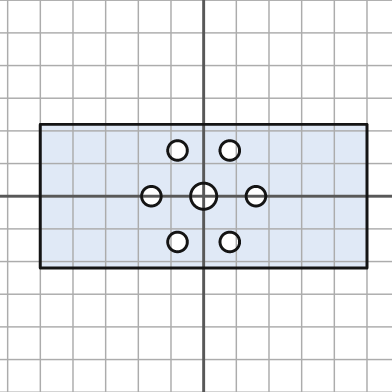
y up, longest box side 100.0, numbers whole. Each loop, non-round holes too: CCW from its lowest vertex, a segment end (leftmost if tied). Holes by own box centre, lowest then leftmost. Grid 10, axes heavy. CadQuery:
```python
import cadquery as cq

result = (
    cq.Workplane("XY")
    .moveTo(-50.0, -22.0)
    .lineTo(50.0, -22.0)
    .lineTo(50.0, 22.0)
    .lineTo(-50.0, 22.0)
    .close()
    .moveTo(-8.0, -14.0)
    .circle(3.0)
    .moveTo(8.0, -14.0)
    .circle(3.0)
    .moveTo(-16.0, 0.0)
    .circle(3.0)
    .moveTo(0.0, 0.0)
    .circle(4.0)
    .moveTo(16.0, 0.0)
    .circle(3.0)
    .moveTo(-8.0, 14.0)
    .circle(3.0)
    .moveTo(8.0, 14.0)
    .circle(3.0)
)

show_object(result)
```